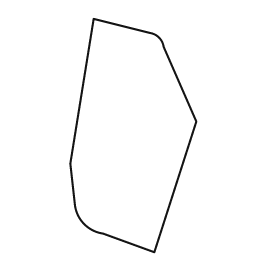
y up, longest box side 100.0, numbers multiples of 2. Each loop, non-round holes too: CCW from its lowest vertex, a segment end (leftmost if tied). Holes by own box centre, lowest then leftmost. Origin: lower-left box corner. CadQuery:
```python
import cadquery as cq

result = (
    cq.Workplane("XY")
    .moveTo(36.0, 0.0)
    .lineTo(54.0, 56.0)
    .lineTo(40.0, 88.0)
    .threePointArc((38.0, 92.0), (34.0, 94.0))
    .lineTo(10.0, 100.0)
    .lineTo(0.0, 38.0)
    .lineTo(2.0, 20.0)
    .threePointArc((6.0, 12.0), (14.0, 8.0))
    .close()
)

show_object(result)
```